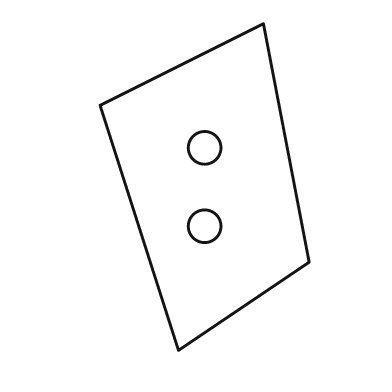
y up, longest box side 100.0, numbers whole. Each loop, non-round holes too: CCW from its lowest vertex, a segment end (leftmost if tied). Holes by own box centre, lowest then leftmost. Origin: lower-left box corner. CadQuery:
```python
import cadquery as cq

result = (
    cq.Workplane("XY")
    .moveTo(24.0, 0.0)
    .lineTo(64.0, 27.0)
    .lineTo(50.0, 100.0)
    .lineTo(0.0, 75.0)
    .close()
    .moveTo(32.0, 38.0)
    .circle(5.0)
    .moveTo(32.0, 62.0)
    .circle(5.0)
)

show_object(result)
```